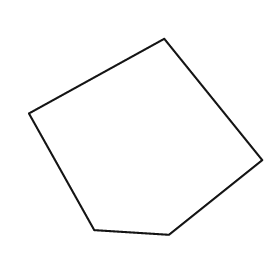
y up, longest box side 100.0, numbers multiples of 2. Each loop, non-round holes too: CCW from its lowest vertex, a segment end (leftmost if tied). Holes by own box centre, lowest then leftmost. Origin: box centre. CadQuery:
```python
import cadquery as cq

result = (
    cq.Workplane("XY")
    .moveTo(10.0, -42.0)
    .lineTo(50.0, -10.0)
    .lineTo(8.0, 42.0)
    .lineTo(-50.0, 10.0)
    .lineTo(-22.0, -40.0)
    .close()
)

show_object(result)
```